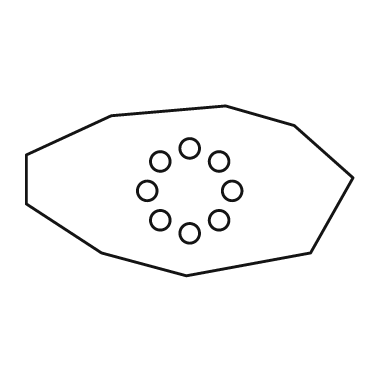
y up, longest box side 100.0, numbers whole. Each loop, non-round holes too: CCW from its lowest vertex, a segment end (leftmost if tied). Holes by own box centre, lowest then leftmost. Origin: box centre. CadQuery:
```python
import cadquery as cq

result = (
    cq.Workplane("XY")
    .moveTo(-1.0, -26.0)
    .lineTo(37.0, -19.0)
    .lineTo(50.0, 4.0)
    .lineTo(32.0, 20.0)
    .lineTo(11.0, 26.0)
    .lineTo(-24.0, 23.0)
    .lineTo(-50.0, 11.0)
    .lineTo(-50.0, -4.0)
    .lineTo(-27.0, -19.0)
    .close()
    .moveTo(0.0, -13.0)
    .circle(3.0)
    .moveTo(-9.0, -9.0)
    .circle(3.0)
    .moveTo(9.0, -9.0)
    .circle(3.0)
    .moveTo(-13.0, 0.0)
    .circle(3.0)
    .moveTo(13.0, 0.0)
    .circle(3.0)
    .moveTo(-9.0, 9.0)
    .circle(3.0)
    .moveTo(9.0, 9.0)
    .circle(3.0)
    .moveTo(0.0, 13.0)
    .circle(3.0)
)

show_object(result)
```